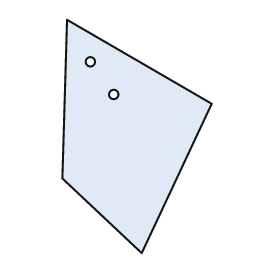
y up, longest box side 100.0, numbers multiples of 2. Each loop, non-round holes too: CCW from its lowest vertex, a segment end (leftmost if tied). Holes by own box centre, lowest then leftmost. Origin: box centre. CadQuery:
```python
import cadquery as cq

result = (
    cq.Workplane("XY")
    .moveTo(2.0, -50.0)
    .lineTo(32.0, 14.0)
    .lineTo(-30.0, 50.0)
    .lineTo(-32.0, -18.0)
    .close()
    .moveTo(-10.0, 18.0)
    .circle(2.0)
    .moveTo(-20.0, 32.0)
    .circle(2.0)
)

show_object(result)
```